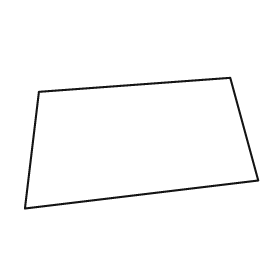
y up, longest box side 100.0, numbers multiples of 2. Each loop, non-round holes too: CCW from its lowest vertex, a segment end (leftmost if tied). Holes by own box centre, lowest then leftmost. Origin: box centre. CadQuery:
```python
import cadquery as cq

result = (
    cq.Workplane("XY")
    .moveTo(-50.0, -28.0)
    .lineTo(50.0, -16.0)
    .lineTo(38.0, 28.0)
    .lineTo(-44.0, 22.0)
    .close()
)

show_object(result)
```